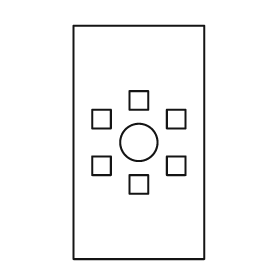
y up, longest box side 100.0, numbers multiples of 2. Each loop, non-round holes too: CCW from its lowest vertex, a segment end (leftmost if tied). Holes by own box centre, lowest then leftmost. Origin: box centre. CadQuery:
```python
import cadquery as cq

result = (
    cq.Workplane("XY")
    .moveTo(-28.0, -50.0)
    .lineTo(28.0, -50.0)
    .lineTo(28.0, 50.0)
    .lineTo(-28.0, 50.0)
    .close()
    .moveTo(-4.0, -22.0)
    .lineTo(4.0, -22.0)
    .lineTo(4.0, -14.0)
    .lineTo(-4.0, -14.0)
    .close()
    .moveTo(-20.0, -14.0)
    .lineTo(-12.0, -14.0)
    .lineTo(-12.0, -6.0)
    .lineTo(-20.0, -6.0)
    .close()
    .moveTo(12.0, -14.0)
    .lineTo(20.0, -14.0)
    .lineTo(20.0, -6.0)
    .lineTo(12.0, -6.0)
    .close()
    .moveTo(0.0, 0.0)
    .circle(8.0)
    .moveTo(-20.0, 6.0)
    .lineTo(-12.0, 6.0)
    .lineTo(-12.0, 14.0)
    .lineTo(-20.0, 14.0)
    .close()
    .moveTo(12.0, 6.0)
    .lineTo(20.0, 6.0)
    .lineTo(20.0, 14.0)
    .lineTo(12.0, 14.0)
    .close()
    .moveTo(-4.0, 14.0)
    .lineTo(4.0, 14.0)
    .lineTo(4.0, 22.0)
    .lineTo(-4.0, 22.0)
    .close()
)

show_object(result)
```